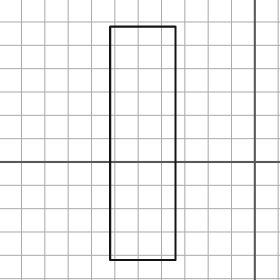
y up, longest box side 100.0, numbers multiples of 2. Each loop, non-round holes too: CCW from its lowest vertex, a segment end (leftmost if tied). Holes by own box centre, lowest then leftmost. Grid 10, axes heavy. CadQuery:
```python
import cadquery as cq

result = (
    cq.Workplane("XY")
    .moveTo(-62.0, -42.0)
    .lineTo(-34.0, -42.0)
    .lineTo(-34.0, 58.0)
    .lineTo(-62.0, 58.0)
    .close()
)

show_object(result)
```